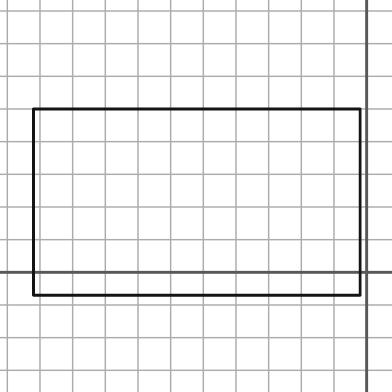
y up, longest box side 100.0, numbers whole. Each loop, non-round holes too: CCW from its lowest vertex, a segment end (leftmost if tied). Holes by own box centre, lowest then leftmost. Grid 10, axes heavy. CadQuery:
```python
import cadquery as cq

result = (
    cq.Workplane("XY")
    .moveTo(-102.0, -7.0)
    .lineTo(-2.0, -7.0)
    .lineTo(-2.0, 50.0)
    .lineTo(-102.0, 50.0)
    .close()
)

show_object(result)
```